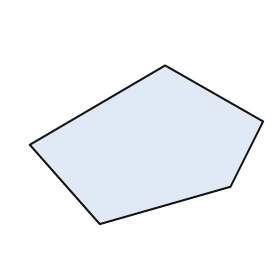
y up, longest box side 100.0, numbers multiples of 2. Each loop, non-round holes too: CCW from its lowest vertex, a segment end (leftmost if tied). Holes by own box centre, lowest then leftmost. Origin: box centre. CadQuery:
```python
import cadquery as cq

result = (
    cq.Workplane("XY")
    .moveTo(-20.0, -34.0)
    .lineTo(36.0, -18.0)
    .lineTo(50.0, 10.0)
    .lineTo(8.0, 34.0)
    .lineTo(-50.0, 0.0)
    .close()
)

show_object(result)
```